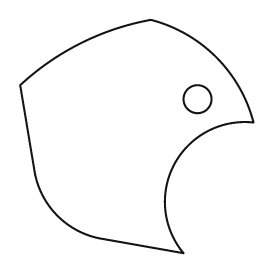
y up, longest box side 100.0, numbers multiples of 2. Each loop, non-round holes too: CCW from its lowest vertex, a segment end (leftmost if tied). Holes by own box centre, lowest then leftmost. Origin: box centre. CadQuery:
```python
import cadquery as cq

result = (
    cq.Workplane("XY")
    .moveTo(20.0, -50.0)
    .threePointArc((16.0, -12.0), (50.0, 6.0))
    .threePointArc((34.0, 34.0), (6.0, 50.0))
    .threePointArc((-24.0, 40.0), (-50.0, 22.0))
    .lineTo(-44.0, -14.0)
    .threePointArc((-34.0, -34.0), (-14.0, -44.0))
    .close()
    .moveTo(26.0, 16.0)
    .circle(6.0)
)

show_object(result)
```